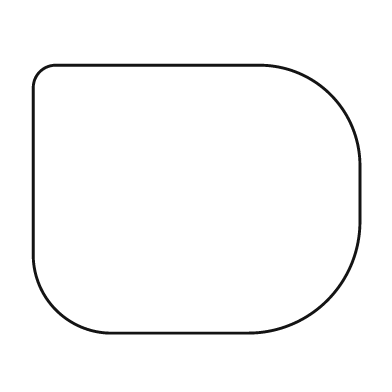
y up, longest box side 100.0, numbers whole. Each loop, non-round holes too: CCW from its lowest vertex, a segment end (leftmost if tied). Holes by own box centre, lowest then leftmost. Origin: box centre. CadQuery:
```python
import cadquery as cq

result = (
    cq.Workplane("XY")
    .moveTo(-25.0, -41.0)
    .lineTo(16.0, -41.0)
    .threePointArc((40.0, -31.0), (50.0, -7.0))
    .lineTo(50.0, 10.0)
    .threePointArc((41.0, 32.0), (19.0, 41.0))
    .lineTo(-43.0, 41.0)
    .threePointArc((-48.0, 39.0), (-50.0, 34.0))
    .lineTo(-50.0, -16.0)
    .threePointArc((-43.0, -34.0), (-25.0, -41.0))
    .close()
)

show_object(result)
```